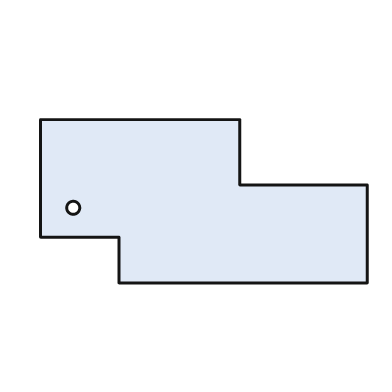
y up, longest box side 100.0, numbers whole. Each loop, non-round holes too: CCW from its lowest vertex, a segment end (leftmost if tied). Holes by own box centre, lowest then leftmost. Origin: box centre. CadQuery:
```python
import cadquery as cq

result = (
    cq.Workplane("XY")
    .moveTo(-26.0, -25.0)
    .lineTo(50.0, -25.0)
    .lineTo(50.0, 5.0)
    .lineTo(11.0, 5.0)
    .lineTo(11.0, 25.0)
    .lineTo(-50.0, 25.0)
    .lineTo(-50.0, -11.0)
    .lineTo(-26.0, -11.0)
    .close()
    .moveTo(-40.0, -2.0)
    .circle(2.0)
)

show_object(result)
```